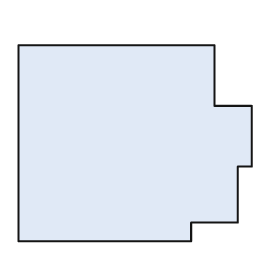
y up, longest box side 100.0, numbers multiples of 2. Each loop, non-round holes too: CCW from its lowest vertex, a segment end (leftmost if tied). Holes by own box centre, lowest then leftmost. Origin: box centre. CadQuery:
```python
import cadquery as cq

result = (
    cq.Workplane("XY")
    .moveTo(-50.0, -42.0)
    .lineTo(24.0, -42.0)
    .lineTo(24.0, -34.0)
    .lineTo(44.0, -34.0)
    .lineTo(44.0, -10.0)
    .lineTo(50.0, -10.0)
    .lineTo(50.0, 16.0)
    .lineTo(34.0, 16.0)
    .lineTo(34.0, 42.0)
    .lineTo(-50.0, 42.0)
    .close()
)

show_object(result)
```